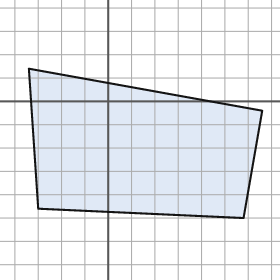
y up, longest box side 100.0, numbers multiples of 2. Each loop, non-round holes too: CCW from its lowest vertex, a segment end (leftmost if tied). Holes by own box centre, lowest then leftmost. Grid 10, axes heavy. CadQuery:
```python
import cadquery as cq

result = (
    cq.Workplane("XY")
    .moveTo(58.0, -50.0)
    .lineTo(66.0, -4.0)
    .lineTo(-34.0, 14.0)
    .lineTo(-30.0, -46.0)
    .close()
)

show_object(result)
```